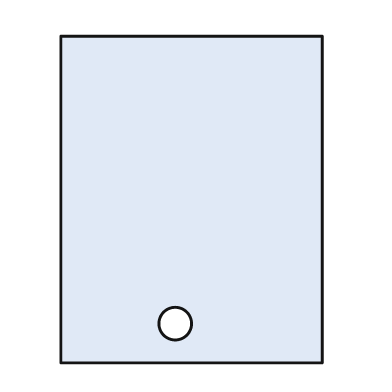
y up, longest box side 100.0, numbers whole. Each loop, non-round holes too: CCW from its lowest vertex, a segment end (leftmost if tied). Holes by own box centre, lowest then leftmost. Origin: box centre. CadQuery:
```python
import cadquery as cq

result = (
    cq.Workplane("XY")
    .moveTo(-40.0, -50.0)
    .lineTo(40.0, -50.0)
    .lineTo(40.0, 50.0)
    .lineTo(-40.0, 50.0)
    .close()
    .moveTo(-5.0, -38.0)
    .circle(5.0)
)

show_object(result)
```